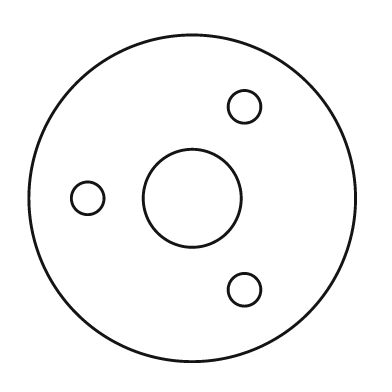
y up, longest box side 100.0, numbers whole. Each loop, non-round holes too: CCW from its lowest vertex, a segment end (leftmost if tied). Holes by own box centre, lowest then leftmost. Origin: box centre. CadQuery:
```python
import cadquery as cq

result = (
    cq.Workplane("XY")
    .moveTo(0.0, 0.0)
    .circle(50.0)
    .moveTo(16.0, -28.0)
    .circle(5.0)
    .moveTo(-32.0, 0.0)
    .circle(5.0)
    .moveTo(0.0, 0.0)
    .circle(15.0)
    .moveTo(16.0, 28.0)
    .circle(5.0)
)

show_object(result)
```